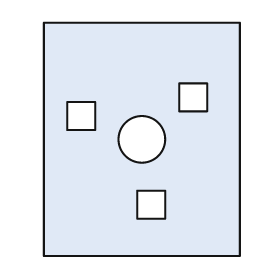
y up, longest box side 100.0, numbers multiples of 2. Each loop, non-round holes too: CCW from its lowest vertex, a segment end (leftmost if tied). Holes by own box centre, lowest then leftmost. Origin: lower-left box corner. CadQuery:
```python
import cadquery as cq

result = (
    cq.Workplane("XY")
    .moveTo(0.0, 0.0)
    .lineTo(84.0, 0.0)
    .lineTo(84.0, 100.0)
    .lineTo(0.0, 100.0)
    .close()
    .moveTo(40.0, 16.0)
    .lineTo(52.0, 16.0)
    .lineTo(52.0, 28.0)
    .lineTo(40.0, 28.0)
    .close()
    .moveTo(42.0, 50.0)
    .circle(10.0)
    .moveTo(10.0, 54.0)
    .lineTo(22.0, 54.0)
    .lineTo(22.0, 66.0)
    .lineTo(10.0, 66.0)
    .close()
    .moveTo(58.0, 62.0)
    .lineTo(70.0, 62.0)
    .lineTo(70.0, 74.0)
    .lineTo(58.0, 74.0)
    .close()
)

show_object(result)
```